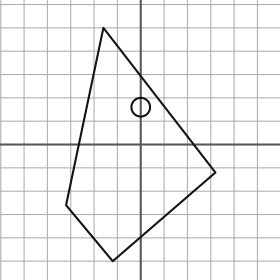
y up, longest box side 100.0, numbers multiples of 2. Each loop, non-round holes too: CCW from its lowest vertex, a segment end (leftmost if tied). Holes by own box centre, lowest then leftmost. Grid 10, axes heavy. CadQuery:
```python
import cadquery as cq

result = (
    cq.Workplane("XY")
    .moveTo(-12.0, -50.0)
    .lineTo(32.0, -12.0)
    .lineTo(-16.0, 50.0)
    .lineTo(-32.0, -26.0)
    .close()
    .moveTo(0.0, 16.0)
    .circle(4.0)
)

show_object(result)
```